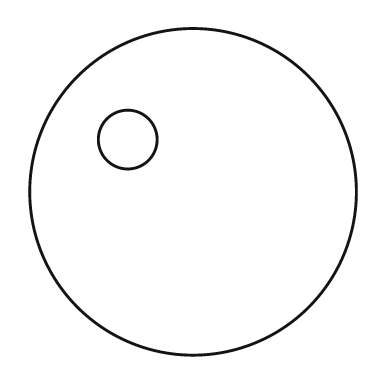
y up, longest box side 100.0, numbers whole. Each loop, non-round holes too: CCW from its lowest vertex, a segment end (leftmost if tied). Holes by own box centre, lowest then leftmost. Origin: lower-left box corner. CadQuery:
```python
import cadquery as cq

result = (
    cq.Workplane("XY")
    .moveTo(50.0, 50.0)
    .circle(50.0)
    .moveTo(30.0, 66.0)
    .circle(9.0)
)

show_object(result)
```